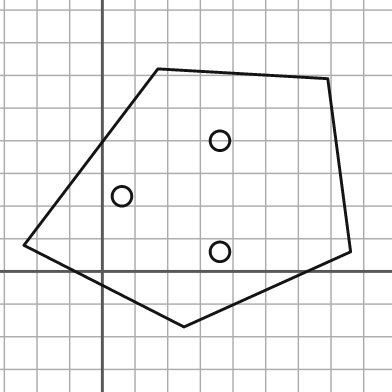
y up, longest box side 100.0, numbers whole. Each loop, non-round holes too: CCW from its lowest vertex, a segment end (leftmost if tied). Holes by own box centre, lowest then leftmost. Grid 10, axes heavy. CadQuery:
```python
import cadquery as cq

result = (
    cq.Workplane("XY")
    .moveTo(25.0, -17.0)
    .lineTo(76.0, 6.0)
    .lineTo(69.0, 59.0)
    .lineTo(17.0, 62.0)
    .lineTo(-24.0, 8.0)
    .close()
    .moveTo(36.0, 6.0)
    .circle(3.0)
    .moveTo(6.0, 23.0)
    .circle(3.0)
    .moveTo(36.0, 40.0)
    .circle(3.0)
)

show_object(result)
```